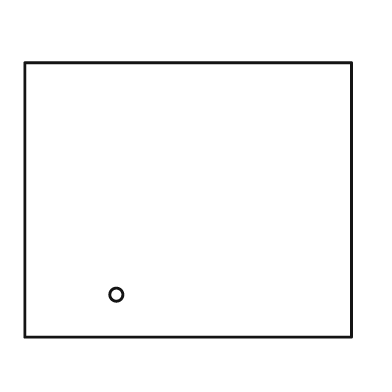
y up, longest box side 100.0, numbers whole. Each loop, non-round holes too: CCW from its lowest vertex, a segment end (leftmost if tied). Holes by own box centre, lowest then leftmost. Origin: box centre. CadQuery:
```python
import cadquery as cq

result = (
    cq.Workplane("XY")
    .moveTo(-50.0, -42.0)
    .lineTo(50.0, -42.0)
    .lineTo(50.0, 42.0)
    .lineTo(-50.0, 42.0)
    .close()
    .moveTo(-22.0, -29.0)
    .circle(2.0)
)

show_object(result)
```